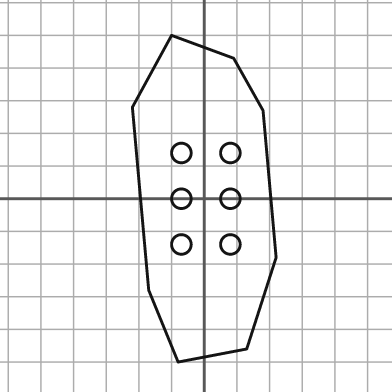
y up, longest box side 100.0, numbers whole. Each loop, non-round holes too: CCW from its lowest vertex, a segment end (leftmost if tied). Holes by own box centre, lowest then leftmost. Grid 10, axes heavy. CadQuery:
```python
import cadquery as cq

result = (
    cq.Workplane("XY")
    .moveTo(-8.0, -50.0)
    .lineTo(13.0, -46.0)
    .lineTo(22.0, -18.0)
    .lineTo(18.0, 27.0)
    .lineTo(9.0, 43.0)
    .lineTo(-10.0, 50.0)
    .lineTo(-22.0, 28.0)
    .lineTo(-17.0, -28.0)
    .close()
    .moveTo(-7.0, -14.0)
    .circle(3.0)
    .moveTo(8.0, -14.0)
    .circle(3.0)
    .moveTo(-7.0, 0.0)
    .circle(3.0)
    .moveTo(8.0, 0.0)
    .circle(3.0)
    .moveTo(-7.0, 14.0)
    .circle(3.0)
    .moveTo(8.0, 14.0)
    .circle(3.0)
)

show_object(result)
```